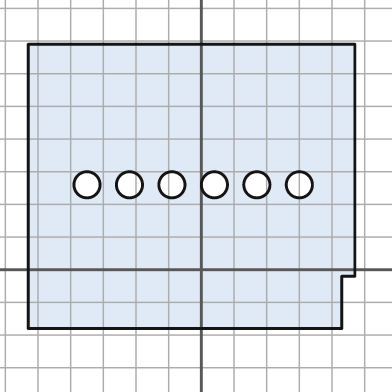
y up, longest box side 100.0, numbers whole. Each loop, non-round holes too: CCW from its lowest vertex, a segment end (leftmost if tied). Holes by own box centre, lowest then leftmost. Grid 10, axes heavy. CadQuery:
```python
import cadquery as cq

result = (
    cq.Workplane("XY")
    .moveTo(-53.0, -18.0)
    .lineTo(43.0, -18.0)
    .lineTo(43.0, -2.0)
    .lineTo(47.0, -2.0)
    .lineTo(47.0, 69.0)
    .lineTo(-53.0, 69.0)
    .close()
    .moveTo(-35.0, 26.0)
    .circle(4.0)
    .moveTo(-22.0, 26.0)
    .circle(4.0)
    .moveTo(-9.0, 26.0)
    .circle(4.0)
    .moveTo(4.0, 26.0)
    .circle(4.0)
    .moveTo(17.0, 26.0)
    .circle(4.0)
    .moveTo(30.0, 26.0)
    .circle(4.0)
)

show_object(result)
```